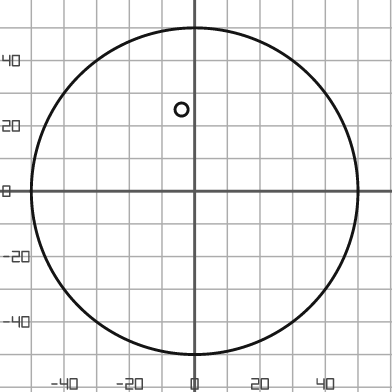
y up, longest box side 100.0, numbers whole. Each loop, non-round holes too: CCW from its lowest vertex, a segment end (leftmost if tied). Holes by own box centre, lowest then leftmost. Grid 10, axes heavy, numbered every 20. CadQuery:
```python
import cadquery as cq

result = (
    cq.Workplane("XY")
    .moveTo(0.0, 0.0)
    .circle(50.0)
    .moveTo(-4.0, 25.0)
    .circle(2.0)
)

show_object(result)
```